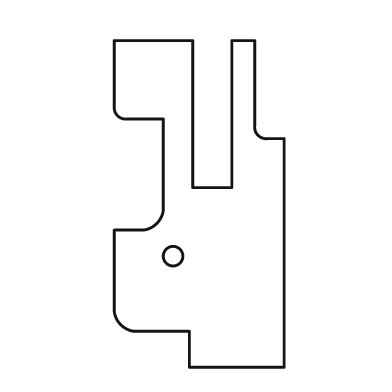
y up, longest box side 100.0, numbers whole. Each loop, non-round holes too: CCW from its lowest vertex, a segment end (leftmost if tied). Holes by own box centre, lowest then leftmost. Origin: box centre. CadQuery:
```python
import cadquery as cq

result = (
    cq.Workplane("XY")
    .moveTo(-3.0, -50.0)
    .lineTo(26.0, -50.0)
    .lineTo(26.0, 20.0)
    .lineTo(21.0, 20.0)
    .threePointArc((18.0, 21.0), (17.0, 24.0))
    .lineTo(17.0, 50.0)
    .lineTo(10.0, 50.0)
    .lineTo(10.0, 5.0)
    .lineTo(-2.0, 5.0)
    .lineTo(-2.0, 50.0)
    .lineTo(-26.0, 50.0)
    .lineTo(-26.0, 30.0)
    .threePointArc((-25.0, 27.0), (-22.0, 26.0))
    .lineTo(-11.0, 26.0)
    .lineTo(-11.0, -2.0)
    .threePointArc((-13.0, -6.0), (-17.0, -8.0))
    .lineTo(-26.0, -8.0)
    .lineTo(-26.0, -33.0)
    .threePointArc((-24.0, -37.0), (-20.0, -39.0))
    .lineTo(-3.0, -39.0)
    .close()
    .moveTo(-8.0, -16.0)
    .circle(3.0)
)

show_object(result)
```